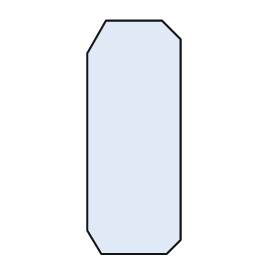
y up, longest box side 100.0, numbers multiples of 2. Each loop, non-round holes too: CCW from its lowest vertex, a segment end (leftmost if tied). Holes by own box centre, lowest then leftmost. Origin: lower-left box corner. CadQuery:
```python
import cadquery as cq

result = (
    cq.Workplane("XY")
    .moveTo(6.0, 0.0)
    .lineTo(34.0, 0.0)
    .lineTo(40.0, 6.0)
    .lineTo(40.0, 92.0)
    .lineTo(32.0, 100.0)
    .lineTo(8.0, 100.0)
    .lineTo(0.0, 86.0)
    .lineTo(0.0, 10.0)
    .close()
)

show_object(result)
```